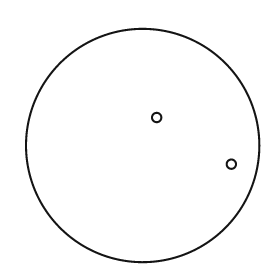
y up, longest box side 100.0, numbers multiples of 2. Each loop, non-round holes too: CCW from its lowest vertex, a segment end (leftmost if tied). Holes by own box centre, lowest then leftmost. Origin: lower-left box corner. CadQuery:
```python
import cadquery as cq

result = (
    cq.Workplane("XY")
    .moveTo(50.0, 50.0)
    .circle(50.0)
    .moveTo(88.0, 42.0)
    .circle(2.0)
    .moveTo(56.0, 62.0)
    .circle(2.0)
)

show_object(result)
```